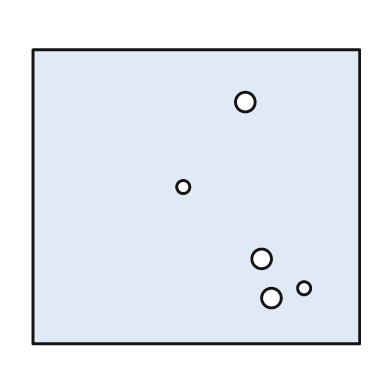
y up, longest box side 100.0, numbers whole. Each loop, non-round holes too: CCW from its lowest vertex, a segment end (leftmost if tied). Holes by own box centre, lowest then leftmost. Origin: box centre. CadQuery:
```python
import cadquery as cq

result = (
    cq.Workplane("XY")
    .moveTo(-50.0, -45.0)
    .lineTo(50.0, -45.0)
    .lineTo(50.0, 45.0)
    .lineTo(-50.0, 45.0)
    .close()
    .moveTo(23.0, -31.0)
    .circle(3.0)
    .moveTo(33.0, -28.0)
    .circle(2.0)
    .moveTo(20.0, -19.0)
    .circle(3.0)
    .moveTo(-4.0, 3.0)
    .circle(2.0)
    .moveTo(15.0, 29.0)
    .circle(3.0)
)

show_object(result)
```